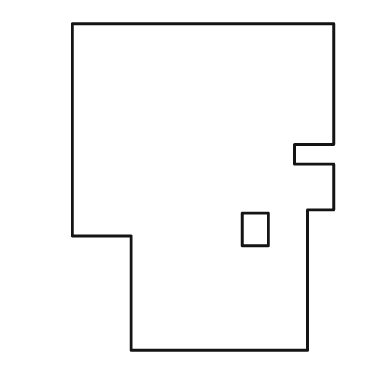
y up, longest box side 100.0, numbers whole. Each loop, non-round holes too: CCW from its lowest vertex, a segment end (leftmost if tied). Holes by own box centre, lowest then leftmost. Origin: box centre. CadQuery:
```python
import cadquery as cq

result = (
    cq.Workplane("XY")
    .moveTo(-22.0, -50.0)
    .lineTo(32.0, -50.0)
    .lineTo(32.0, -7.0)
    .lineTo(40.0, -7.0)
    .lineTo(40.0, 7.0)
    .lineTo(28.0, 7.0)
    .lineTo(28.0, 13.0)
    .lineTo(40.0, 13.0)
    .lineTo(40.0, 50.0)
    .lineTo(-40.0, 50.0)
    .lineTo(-40.0, -15.0)
    .lineTo(-22.0, -15.0)
    .close()
    .moveTo(12.0, -18.0)
    .lineTo(20.0, -18.0)
    .lineTo(20.0, -8.0)
    .lineTo(12.0, -8.0)
    .close()
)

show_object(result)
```